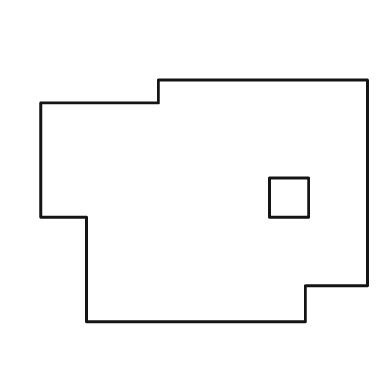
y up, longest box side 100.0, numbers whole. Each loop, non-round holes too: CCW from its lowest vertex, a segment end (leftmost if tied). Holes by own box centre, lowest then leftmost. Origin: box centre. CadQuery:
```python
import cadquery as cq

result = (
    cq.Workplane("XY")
    .moveTo(-36.0, -37.0)
    .lineTo(31.0, -37.0)
    .lineTo(31.0, -26.0)
    .lineTo(50.0, -26.0)
    .lineTo(50.0, 37.0)
    .lineTo(-14.0, 37.0)
    .lineTo(-14.0, 30.0)
    .lineTo(-50.0, 30.0)
    .lineTo(-50.0, -5.0)
    .lineTo(-36.0, -5.0)
    .close()
    .moveTo(20.0, -5.0)
    .lineTo(32.0, -5.0)
    .lineTo(32.0, 7.0)
    .lineTo(20.0, 7.0)
    .close()
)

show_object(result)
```